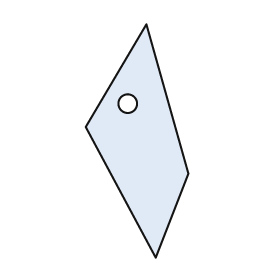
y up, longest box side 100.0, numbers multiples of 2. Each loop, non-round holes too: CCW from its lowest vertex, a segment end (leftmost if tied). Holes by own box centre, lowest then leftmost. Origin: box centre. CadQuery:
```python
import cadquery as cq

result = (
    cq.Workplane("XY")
    .moveTo(8.0, -50.0)
    .lineTo(22.0, -14.0)
    .lineTo(4.0, 50.0)
    .lineTo(-22.0, 6.0)
    .close()
    .moveTo(-4.0, 16.0)
    .circle(4.0)
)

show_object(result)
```